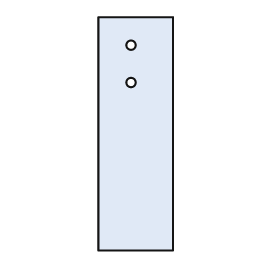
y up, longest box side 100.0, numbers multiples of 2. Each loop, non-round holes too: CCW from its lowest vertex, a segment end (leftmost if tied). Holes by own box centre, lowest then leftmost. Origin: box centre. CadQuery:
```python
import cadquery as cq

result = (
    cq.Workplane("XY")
    .moveTo(-16.0, -50.0)
    .lineTo(16.0, -50.0)
    .lineTo(16.0, 50.0)
    .lineTo(-16.0, 50.0)
    .close()
    .moveTo(-2.0, 22.0)
    .circle(2.0)
    .moveTo(-2.0, 38.0)
    .circle(2.0)
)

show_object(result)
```